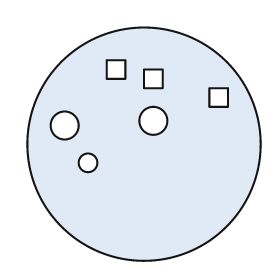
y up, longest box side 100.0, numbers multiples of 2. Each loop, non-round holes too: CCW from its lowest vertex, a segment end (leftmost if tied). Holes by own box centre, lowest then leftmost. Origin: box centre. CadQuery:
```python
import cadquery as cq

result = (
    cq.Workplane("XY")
    .moveTo(0.0, 0.0)
    .circle(50.0)
    .moveTo(-24.0, -8.0)
    .circle(4.0)
    .moveTo(-34.0, 8.0)
    .circle(6.0)
    .moveTo(4.0, 10.0)
    .circle(6.0)
    .moveTo(28.0, 16.0)
    .lineTo(36.0, 16.0)
    .lineTo(36.0, 24.0)
    .lineTo(28.0, 24.0)
    .close()
    .moveTo(0.0, 24.0)
    .lineTo(8.0, 24.0)
    .lineTo(8.0, 32.0)
    .lineTo(0.0, 32.0)
    .close()
    .moveTo(-16.0, 28.0)
    .lineTo(-8.0, 28.0)
    .lineTo(-8.0, 36.0)
    .lineTo(-16.0, 36.0)
    .close()
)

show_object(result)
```